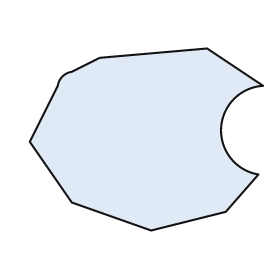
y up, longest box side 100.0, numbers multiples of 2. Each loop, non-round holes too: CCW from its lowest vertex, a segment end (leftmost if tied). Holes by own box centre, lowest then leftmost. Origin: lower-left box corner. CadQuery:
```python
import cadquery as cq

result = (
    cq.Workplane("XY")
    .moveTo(52.0, 0.0)
    .lineTo(84.0, 8.0)
    .lineTo(98.0, 24.0)
    .threePointArc((82.0, 44.0), (100.0, 62.0))
    .lineTo(76.0, 78.0)
    .lineTo(30.0, 74.0)
    .lineTo(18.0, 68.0)
    .threePointArc((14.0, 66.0), (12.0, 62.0))
    .lineTo(0.0, 38.0)
    .lineTo(18.0, 12.0)
    .close()
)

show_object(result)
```